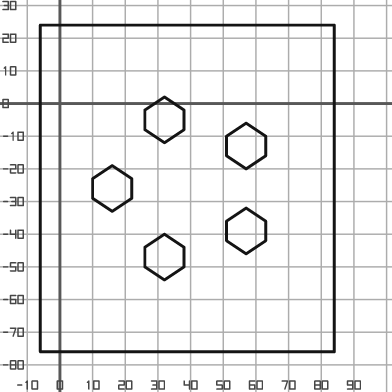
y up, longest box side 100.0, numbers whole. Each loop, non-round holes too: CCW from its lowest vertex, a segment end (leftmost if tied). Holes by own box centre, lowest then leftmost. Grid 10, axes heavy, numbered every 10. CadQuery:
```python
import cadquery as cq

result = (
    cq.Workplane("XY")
    .moveTo(-6.0, -76.0)
    .lineTo(84.0, -76.0)
    .lineTo(84.0, 24.0)
    .lineTo(-6.0, 24.0)
    .close()
    .moveTo(32.0, -54.0)
    .lineTo(38.0, -50.0)
    .lineTo(38.0, -44.0)
    .lineTo(32.0, -40.0)
    .lineTo(26.0, -44.0)
    .lineTo(26.0, -50.0)
    .close()
    .moveTo(57.0, -46.0)
    .lineTo(63.0, -42.0)
    .lineTo(63.0, -36.0)
    .lineTo(57.0, -32.0)
    .lineTo(51.0, -36.0)
    .lineTo(51.0, -42.0)
    .close()
    .moveTo(16.0, -33.0)
    .lineTo(22.0, -29.0)
    .lineTo(22.0, -23.0)
    .lineTo(16.0, -19.0)
    .lineTo(10.0, -23.0)
    .lineTo(10.0, -29.0)
    .close()
    .moveTo(57.0, -20.0)
    .lineTo(63.0, -16.0)
    .lineTo(63.0, -10.0)
    .lineTo(57.0, -6.0)
    .lineTo(51.0, -10.0)
    .lineTo(51.0, -16.0)
    .close()
    .moveTo(32.0, -12.0)
    .lineTo(38.0, -8.0)
    .lineTo(38.0, -2.0)
    .lineTo(32.0, 2.0)
    .lineTo(26.0, -2.0)
    .lineTo(26.0, -8.0)
    .close()
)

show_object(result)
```